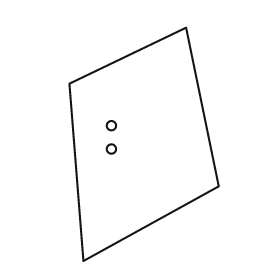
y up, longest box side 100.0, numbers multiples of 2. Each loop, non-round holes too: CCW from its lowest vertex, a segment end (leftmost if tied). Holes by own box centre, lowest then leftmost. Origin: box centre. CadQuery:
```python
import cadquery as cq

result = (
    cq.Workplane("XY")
    .moveTo(-26.0, -50.0)
    .lineTo(32.0, -18.0)
    .lineTo(18.0, 50.0)
    .lineTo(-32.0, 26.0)
    .close()
    .moveTo(-14.0, -2.0)
    .circle(2.0)
    .moveTo(-14.0, 8.0)
    .circle(2.0)
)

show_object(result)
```